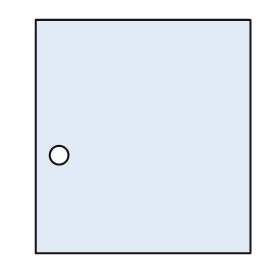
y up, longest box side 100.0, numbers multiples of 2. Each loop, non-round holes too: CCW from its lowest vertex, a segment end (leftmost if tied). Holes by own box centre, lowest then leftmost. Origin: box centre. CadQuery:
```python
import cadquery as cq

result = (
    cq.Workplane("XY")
    .moveTo(-46.0, -50.0)
    .lineTo(46.0, -50.0)
    .lineTo(46.0, 50.0)
    .lineTo(-46.0, 50.0)
    .close()
    .moveTo(-36.0, -8.0)
    .circle(4.0)
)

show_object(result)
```